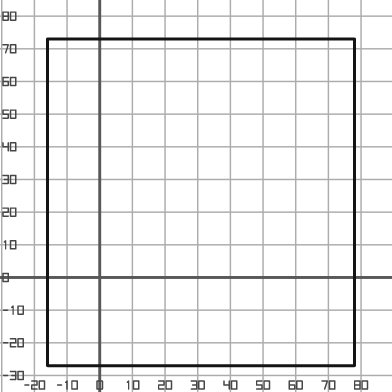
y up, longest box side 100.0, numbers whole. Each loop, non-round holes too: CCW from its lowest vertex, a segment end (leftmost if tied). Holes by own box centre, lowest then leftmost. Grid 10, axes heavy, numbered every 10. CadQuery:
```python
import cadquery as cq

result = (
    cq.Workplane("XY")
    .moveTo(-16.0, -27.0)
    .lineTo(78.0, -27.0)
    .lineTo(78.0, 73.0)
    .lineTo(-16.0, 73.0)
    .close()
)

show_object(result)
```